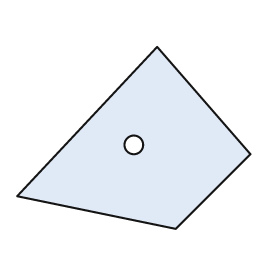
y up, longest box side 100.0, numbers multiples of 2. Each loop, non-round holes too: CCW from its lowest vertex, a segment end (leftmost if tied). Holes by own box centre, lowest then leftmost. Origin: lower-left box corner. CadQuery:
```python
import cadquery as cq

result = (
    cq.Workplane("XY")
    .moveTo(68.0, 0.0)
    .lineTo(100.0, 32.0)
    .lineTo(60.0, 78.0)
    .lineTo(0.0, 14.0)
    .close()
    .moveTo(50.0, 36.0)
    .circle(4.0)
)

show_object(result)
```